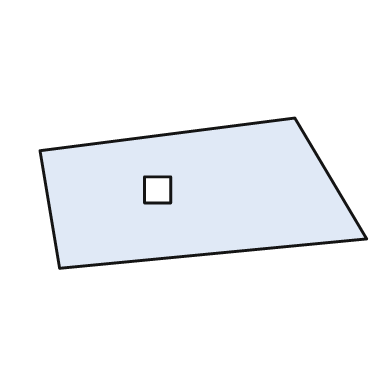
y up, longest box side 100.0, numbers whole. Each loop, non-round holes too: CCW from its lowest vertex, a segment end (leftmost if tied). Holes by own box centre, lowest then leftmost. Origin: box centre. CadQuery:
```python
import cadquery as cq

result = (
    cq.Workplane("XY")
    .moveTo(-44.0, -23.0)
    .lineTo(50.0, -14.0)
    .lineTo(28.0, 23.0)
    .lineTo(-50.0, 13.0)
    .close()
    .moveTo(-18.0, -3.0)
    .lineTo(-10.0, -3.0)
    .lineTo(-10.0, 5.0)
    .lineTo(-18.0, 5.0)
    .close()
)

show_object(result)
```